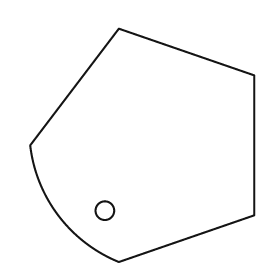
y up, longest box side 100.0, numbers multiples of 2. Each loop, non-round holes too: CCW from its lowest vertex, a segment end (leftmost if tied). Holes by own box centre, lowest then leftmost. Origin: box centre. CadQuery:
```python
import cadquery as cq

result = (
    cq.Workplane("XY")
    .moveTo(-10.0, -50.0)
    .lineTo(48.0, -30.0)
    .lineTo(48.0, 30.0)
    .lineTo(-10.0, 50.0)
    .lineTo(-48.0, 0.0)
    .threePointArc((-36.0, -30.0), (-10.0, -50.0))
    .close()
    .moveTo(-16.0, -28.0)
    .circle(4.0)
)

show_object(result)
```